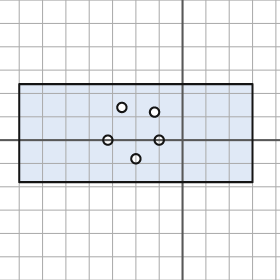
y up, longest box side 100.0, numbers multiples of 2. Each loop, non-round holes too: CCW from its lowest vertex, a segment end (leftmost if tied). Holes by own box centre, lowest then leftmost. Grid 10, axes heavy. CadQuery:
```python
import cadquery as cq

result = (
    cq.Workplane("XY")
    .moveTo(-70.0, -18.0)
    .lineTo(30.0, -18.0)
    .lineTo(30.0, 24.0)
    .lineTo(-70.0, 24.0)
    .close()
    .moveTo(-20.0, -8.0)
    .circle(2.0)
    .moveTo(-32.0, 0.0)
    .circle(2.0)
    .moveTo(-10.0, 0.0)
    .circle(2.0)
    .moveTo(-12.0, 12.0)
    .circle(2.0)
    .moveTo(-26.0, 14.0)
    .circle(2.0)
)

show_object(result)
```